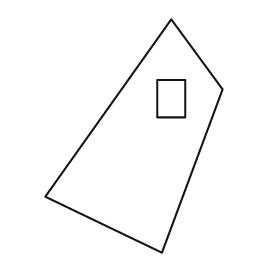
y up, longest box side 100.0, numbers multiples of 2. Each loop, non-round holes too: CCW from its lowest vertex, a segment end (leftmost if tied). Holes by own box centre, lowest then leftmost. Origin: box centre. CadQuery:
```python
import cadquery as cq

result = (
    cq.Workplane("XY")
    .moveTo(12.0, -50.0)
    .lineTo(38.0, 20.0)
    .lineTo(16.0, 50.0)
    .lineTo(-38.0, -26.0)
    .close()
    .moveTo(10.0, 8.0)
    .lineTo(22.0, 8.0)
    .lineTo(22.0, 24.0)
    .lineTo(10.0, 24.0)
    .close()
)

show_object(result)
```